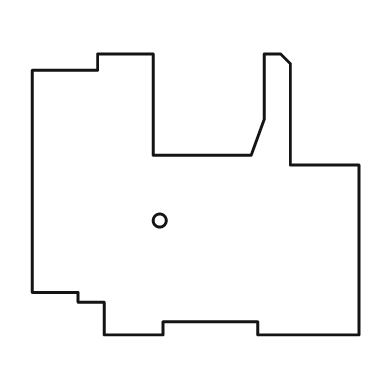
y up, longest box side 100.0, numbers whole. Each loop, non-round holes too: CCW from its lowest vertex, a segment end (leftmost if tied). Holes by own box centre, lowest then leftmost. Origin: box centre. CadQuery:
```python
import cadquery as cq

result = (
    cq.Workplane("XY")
    .moveTo(-28.0, -43.0)
    .lineTo(-10.0, -43.0)
    .lineTo(-10.0, -39.0)
    .lineTo(19.0, -39.0)
    .lineTo(19.0, -43.0)
    .lineTo(50.0, -43.0)
    .lineTo(50.0, 9.0)
    .lineTo(29.0, 9.0)
    .lineTo(29.0, 40.0)
    .lineTo(26.0, 43.0)
    .lineTo(21.0, 43.0)
    .lineTo(21.0, 23.0)
    .lineTo(17.0, 12.0)
    .lineTo(-13.0, 12.0)
    .lineTo(-13.0, 43.0)
    .lineTo(-30.0, 43.0)
    .lineTo(-30.0, 38.0)
    .lineTo(-50.0, 38.0)
    .lineTo(-50.0, -30.0)
    .lineTo(-36.0, -30.0)
    .lineTo(-36.0, -33.0)
    .lineTo(-28.0, -33.0)
    .close()
    .moveTo(-11.0, -8.0)
    .circle(2.0)
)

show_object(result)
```